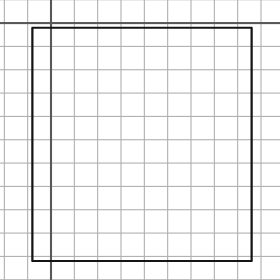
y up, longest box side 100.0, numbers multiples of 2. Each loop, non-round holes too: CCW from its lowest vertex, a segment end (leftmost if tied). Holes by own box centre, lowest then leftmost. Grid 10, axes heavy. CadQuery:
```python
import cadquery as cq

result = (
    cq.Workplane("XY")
    .moveTo(-8.0, -102.0)
    .lineTo(86.0, -102.0)
    .lineTo(86.0, -2.0)
    .lineTo(-8.0, -2.0)
    .close()
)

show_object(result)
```